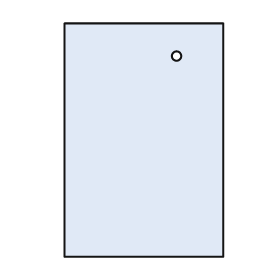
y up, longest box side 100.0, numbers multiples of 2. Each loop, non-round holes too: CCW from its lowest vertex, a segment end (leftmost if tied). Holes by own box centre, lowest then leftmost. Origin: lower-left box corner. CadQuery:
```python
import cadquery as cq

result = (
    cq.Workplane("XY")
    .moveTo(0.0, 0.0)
    .lineTo(68.0, 0.0)
    .lineTo(68.0, 100.0)
    .lineTo(0.0, 100.0)
    .close()
    .moveTo(48.0, 86.0)
    .circle(2.0)
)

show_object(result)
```